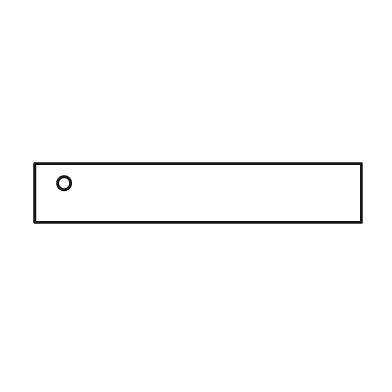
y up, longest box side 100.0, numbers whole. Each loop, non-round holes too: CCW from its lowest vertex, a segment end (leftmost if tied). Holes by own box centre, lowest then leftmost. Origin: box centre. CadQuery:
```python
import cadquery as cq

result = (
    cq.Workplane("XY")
    .moveTo(-50.0, -9.0)
    .lineTo(50.0, -9.0)
    .lineTo(50.0, 9.0)
    .lineTo(-50.0, 9.0)
    .close()
    .moveTo(-41.0, 3.0)
    .circle(2.0)
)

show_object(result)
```